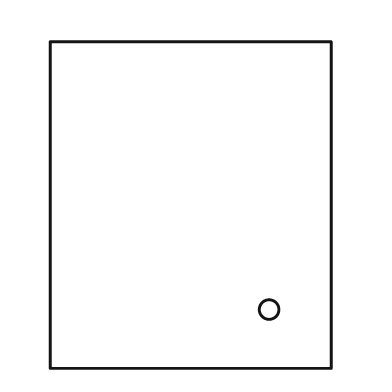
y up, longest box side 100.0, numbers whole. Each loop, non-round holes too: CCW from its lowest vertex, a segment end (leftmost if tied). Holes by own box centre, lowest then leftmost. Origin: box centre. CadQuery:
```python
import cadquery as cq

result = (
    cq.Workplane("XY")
    .moveTo(-43.0, -50.0)
    .lineTo(43.0, -50.0)
    .lineTo(43.0, 50.0)
    .lineTo(-43.0, 50.0)
    .close()
    .moveTo(24.0, -32.0)
    .circle(3.0)
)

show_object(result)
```